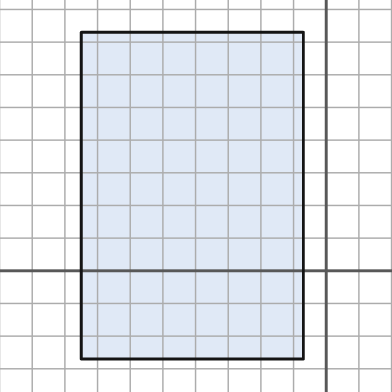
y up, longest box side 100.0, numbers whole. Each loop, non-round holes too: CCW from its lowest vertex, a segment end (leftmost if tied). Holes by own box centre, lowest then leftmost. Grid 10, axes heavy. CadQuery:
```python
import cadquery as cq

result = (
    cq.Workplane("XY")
    .moveTo(-75.0, -27.0)
    .lineTo(-7.0, -27.0)
    .lineTo(-7.0, 73.0)
    .lineTo(-75.0, 73.0)
    .close()
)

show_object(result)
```